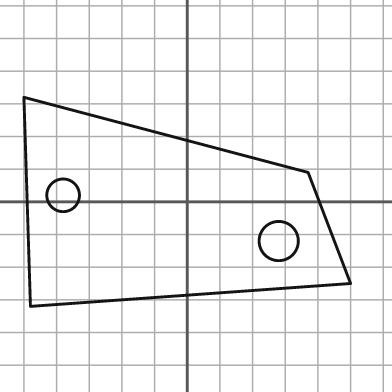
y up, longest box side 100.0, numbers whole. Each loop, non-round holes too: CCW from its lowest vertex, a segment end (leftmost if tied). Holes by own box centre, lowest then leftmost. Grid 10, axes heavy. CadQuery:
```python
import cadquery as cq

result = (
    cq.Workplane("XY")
    .moveTo(-48.0, -32.0)
    .lineTo(50.0, -25.0)
    .lineTo(37.0, 9.0)
    .lineTo(-50.0, 32.0)
    .close()
    .moveTo(28.0, -12.0)
    .circle(6.0)
    .moveTo(-38.0, 2.0)
    .circle(5.0)
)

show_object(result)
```